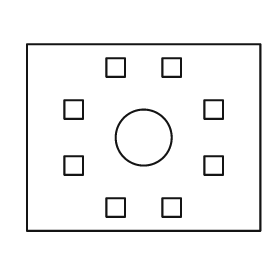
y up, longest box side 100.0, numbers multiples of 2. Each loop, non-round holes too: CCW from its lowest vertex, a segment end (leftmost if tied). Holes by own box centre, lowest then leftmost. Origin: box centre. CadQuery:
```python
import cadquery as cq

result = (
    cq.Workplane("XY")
    .moveTo(-50.0, -40.0)
    .lineTo(50.0, -40.0)
    .lineTo(50.0, 40.0)
    .lineTo(-50.0, 40.0)
    .close()
    .moveTo(-16.0, -34.0)
    .lineTo(-8.0, -34.0)
    .lineTo(-8.0, -26.0)
    .lineTo(-16.0, -26.0)
    .close()
    .moveTo(8.0, -34.0)
    .lineTo(16.0, -34.0)
    .lineTo(16.0, -26.0)
    .lineTo(8.0, -26.0)
    .close()
    .moveTo(-34.0, -16.0)
    .lineTo(-26.0, -16.0)
    .lineTo(-26.0, -8.0)
    .lineTo(-34.0, -8.0)
    .close()
    .moveTo(26.0, -16.0)
    .lineTo(34.0, -16.0)
    .lineTo(34.0, -8.0)
    .lineTo(26.0, -8.0)
    .close()
    .moveTo(0.0, 0.0)
    .circle(12.0)
    .moveTo(-34.0, 8.0)
    .lineTo(-26.0, 8.0)
    .lineTo(-26.0, 16.0)
    .lineTo(-34.0, 16.0)
    .close()
    .moveTo(26.0, 8.0)
    .lineTo(34.0, 8.0)
    .lineTo(34.0, 16.0)
    .lineTo(26.0, 16.0)
    .close()
    .moveTo(-16.0, 26.0)
    .lineTo(-8.0, 26.0)
    .lineTo(-8.0, 34.0)
    .lineTo(-16.0, 34.0)
    .close()
    .moveTo(8.0, 26.0)
    .lineTo(16.0, 26.0)
    .lineTo(16.0, 34.0)
    .lineTo(8.0, 34.0)
    .close()
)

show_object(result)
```